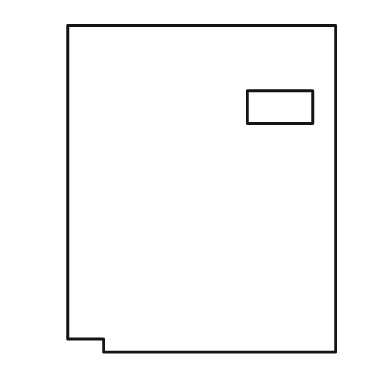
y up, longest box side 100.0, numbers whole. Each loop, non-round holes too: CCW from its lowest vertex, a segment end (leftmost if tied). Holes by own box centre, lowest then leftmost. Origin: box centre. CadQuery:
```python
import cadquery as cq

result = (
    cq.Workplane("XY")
    .moveTo(-30.0, -50.0)
    .lineTo(41.0, -50.0)
    .lineTo(41.0, 50.0)
    .lineTo(-41.0, 50.0)
    .lineTo(-41.0, -46.0)
    .lineTo(-30.0, -46.0)
    .close()
    .moveTo(14.0, 20.0)
    .lineTo(34.0, 20.0)
    .lineTo(34.0, 30.0)
    .lineTo(14.0, 30.0)
    .close()
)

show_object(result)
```